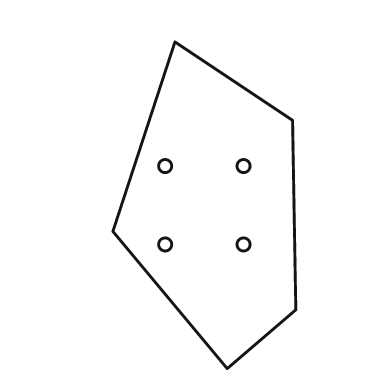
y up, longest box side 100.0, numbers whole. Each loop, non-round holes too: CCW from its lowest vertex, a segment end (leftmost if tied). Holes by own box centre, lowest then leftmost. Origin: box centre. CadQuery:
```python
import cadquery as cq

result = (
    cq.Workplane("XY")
    .moveTo(7.0, -50.0)
    .lineTo(28.0, -32.0)
    .lineTo(27.0, 26.0)
    .lineTo(-9.0, 50.0)
    .lineTo(-28.0, -8.0)
    .close()
    .moveTo(-12.0, -12.0)
    .circle(2.0)
    .moveTo(12.0, -12.0)
    .circle(2.0)
    .moveTo(-12.0, 12.0)
    .circle(2.0)
    .moveTo(12.0, 12.0)
    .circle(2.0)
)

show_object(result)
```